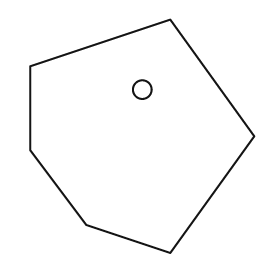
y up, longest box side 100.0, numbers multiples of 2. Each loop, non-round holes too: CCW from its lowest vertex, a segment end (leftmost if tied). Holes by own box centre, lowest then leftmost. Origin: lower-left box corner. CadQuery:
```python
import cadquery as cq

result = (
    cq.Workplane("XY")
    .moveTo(60.0, 0.0)
    .lineTo(96.0, 50.0)
    .lineTo(60.0, 100.0)
    .lineTo(0.0, 80.0)
    .lineTo(0.0, 44.0)
    .lineTo(24.0, 12.0)
    .close()
    .moveTo(48.0, 70.0)
    .circle(4.0)
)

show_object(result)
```